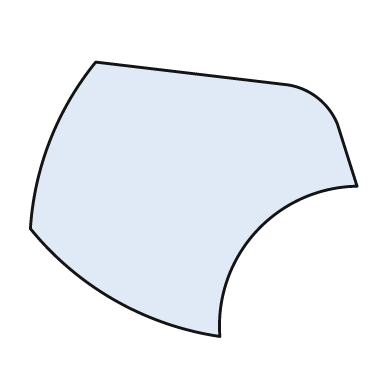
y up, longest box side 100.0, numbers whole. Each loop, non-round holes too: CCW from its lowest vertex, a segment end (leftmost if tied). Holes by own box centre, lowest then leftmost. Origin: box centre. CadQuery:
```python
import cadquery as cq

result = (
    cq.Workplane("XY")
    .moveTo(8.0, -42.0)
    .threePointArc((19.0, -10.0), (50.0, 4.0))
    .lineTo(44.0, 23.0)
    .threePointArc((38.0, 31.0), (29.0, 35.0))
    .lineTo(-30.0, 42.0)
    .threePointArc((-44.0, 18.0), (-50.0, -9.0))
    .threePointArc((-24.0, -31.0), (8.0, -42.0))
    .close()
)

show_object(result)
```